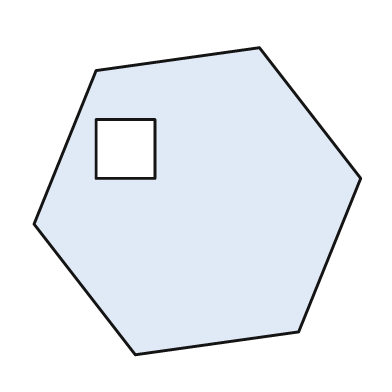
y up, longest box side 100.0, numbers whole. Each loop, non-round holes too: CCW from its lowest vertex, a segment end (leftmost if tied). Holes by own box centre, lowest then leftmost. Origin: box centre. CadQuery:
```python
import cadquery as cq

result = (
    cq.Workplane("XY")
    .moveTo(-19.0, -47.0)
    .lineTo(31.0, -40.0)
    .lineTo(50.0, 7.0)
    .lineTo(19.0, 47.0)
    .lineTo(-31.0, 40.0)
    .lineTo(-50.0, -7.0)
    .close()
    .moveTo(-31.0, 7.0)
    .lineTo(-13.0, 7.0)
    .lineTo(-13.0, 25.0)
    .lineTo(-31.0, 25.0)
    .close()
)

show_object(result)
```